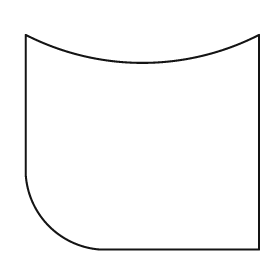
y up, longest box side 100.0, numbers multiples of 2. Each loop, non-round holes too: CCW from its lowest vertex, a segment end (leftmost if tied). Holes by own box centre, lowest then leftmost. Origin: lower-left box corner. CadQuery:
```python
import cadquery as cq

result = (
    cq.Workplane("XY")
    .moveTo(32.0, 0.0)
    .lineTo(100.0, 0.0)
    .lineTo(100.0, 92.0)
    .threePointArc((50.0, 80.0), (0.0, 92.0))
    .lineTo(0.0, 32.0)
    .threePointArc((10.0, 10.0), (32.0, 0.0))
    .close()
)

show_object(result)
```